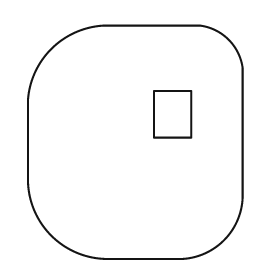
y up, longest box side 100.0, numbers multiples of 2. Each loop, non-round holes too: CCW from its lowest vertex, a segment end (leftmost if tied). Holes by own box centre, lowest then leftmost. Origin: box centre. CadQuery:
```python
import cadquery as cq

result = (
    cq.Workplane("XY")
    .moveTo(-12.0, -50.0)
    .lineTo(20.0, -50.0)
    .threePointArc((38.0, -42.0), (46.0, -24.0))
    .lineTo(46.0, 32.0)
    .threePointArc((40.0, 44.0), (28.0, 50.0))
    .lineTo(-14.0, 50.0)
    .threePointArc((-36.0, 40.0), (-46.0, 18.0))
    .lineTo(-46.0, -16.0)
    .threePointArc((-36.0, -40.0), (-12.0, -50.0))
    .close()
    .moveTo(8.0, 2.0)
    .lineTo(24.0, 2.0)
    .lineTo(24.0, 22.0)
    .lineTo(8.0, 22.0)
    .close()
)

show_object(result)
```